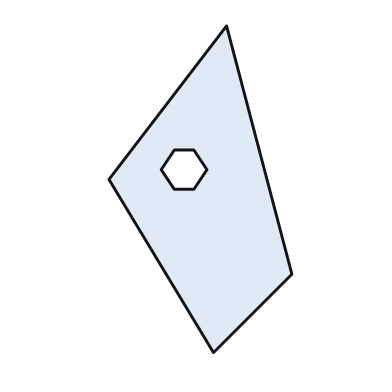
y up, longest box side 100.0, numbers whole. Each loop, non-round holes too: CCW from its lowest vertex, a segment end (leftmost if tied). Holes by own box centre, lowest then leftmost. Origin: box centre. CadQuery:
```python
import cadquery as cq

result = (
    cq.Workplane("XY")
    .moveTo(4.0, -50.0)
    .lineTo(28.0, -26.0)
    .lineTo(8.0, 50.0)
    .lineTo(-28.0, 3.0)
    .close()
    .moveTo(-8.0, 0.0)
    .lineTo(-2.0, 0.0)
    .lineTo(2.0, 6.0)
    .lineTo(-2.0, 12.0)
    .lineTo(-8.0, 12.0)
    .lineTo(-12.0, 6.0)
    .close()
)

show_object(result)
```